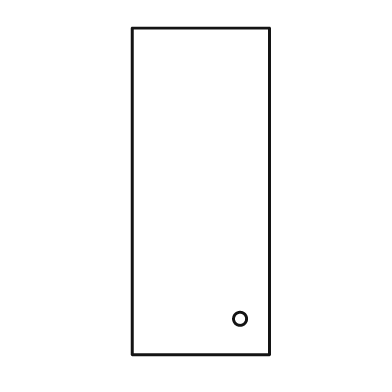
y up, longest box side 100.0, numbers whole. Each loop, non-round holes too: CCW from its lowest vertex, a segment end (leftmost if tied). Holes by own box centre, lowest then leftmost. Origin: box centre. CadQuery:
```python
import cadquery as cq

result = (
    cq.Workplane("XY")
    .moveTo(-21.0, -50.0)
    .lineTo(21.0, -50.0)
    .lineTo(21.0, 50.0)
    .lineTo(-21.0, 50.0)
    .close()
    .moveTo(12.0, -39.0)
    .circle(2.0)
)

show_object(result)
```